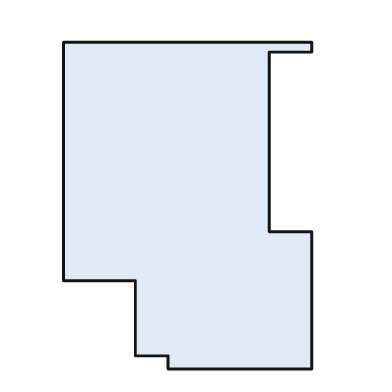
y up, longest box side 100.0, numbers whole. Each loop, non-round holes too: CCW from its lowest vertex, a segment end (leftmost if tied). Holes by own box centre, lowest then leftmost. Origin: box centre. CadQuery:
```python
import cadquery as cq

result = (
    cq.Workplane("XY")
    .moveTo(-6.0, -50.0)
    .lineTo(38.0, -50.0)
    .lineTo(38.0, -8.0)
    .lineTo(25.0, -8.0)
    .lineTo(25.0, 47.0)
    .lineTo(38.0, 47.0)
    .lineTo(38.0, 50.0)
    .lineTo(-38.0, 50.0)
    .lineTo(-38.0, -23.0)
    .lineTo(-16.0, -23.0)
    .lineTo(-16.0, -46.0)
    .lineTo(-6.0, -46.0)
    .close()
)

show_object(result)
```